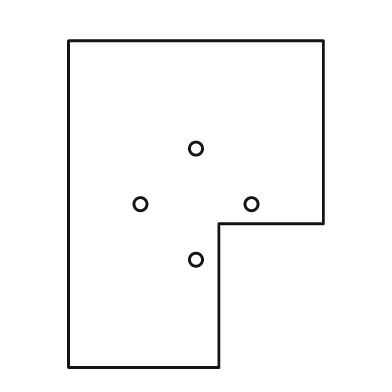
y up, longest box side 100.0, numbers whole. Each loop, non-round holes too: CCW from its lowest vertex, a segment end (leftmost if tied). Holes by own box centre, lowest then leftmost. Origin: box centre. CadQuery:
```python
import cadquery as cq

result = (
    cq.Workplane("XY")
    .moveTo(-39.0, -50.0)
    .lineTo(7.0, -50.0)
    .lineTo(7.0, -6.0)
    .lineTo(39.0, -6.0)
    .lineTo(39.0, 50.0)
    .lineTo(-39.0, 50.0)
    .close()
    .moveTo(0.0, -17.0)
    .circle(2.0)
    .moveTo(-17.0, 0.0)
    .circle(2.0)
    .moveTo(17.0, 0.0)
    .circle(2.0)
    .moveTo(0.0, 17.0)
    .circle(2.0)
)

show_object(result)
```